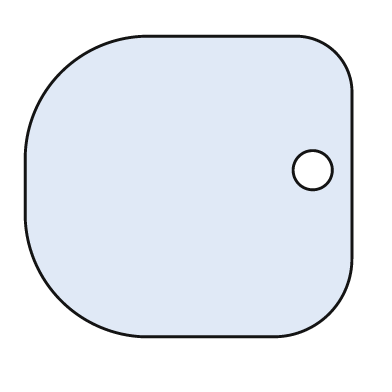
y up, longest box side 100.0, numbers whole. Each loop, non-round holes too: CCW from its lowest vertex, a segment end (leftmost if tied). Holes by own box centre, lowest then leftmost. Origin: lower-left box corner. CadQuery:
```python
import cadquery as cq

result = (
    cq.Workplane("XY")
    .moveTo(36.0, 0.0)
    .lineTo(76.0, 0.0)
    .threePointArc((93.0, 7.0), (100.0, 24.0))
    .lineTo(100.0, 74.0)
    .threePointArc((95.0, 87.0), (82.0, 92.0))
    .lineTo(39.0, 92.0)
    .threePointArc((11.0, 81.0), (0.0, 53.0))
    .lineTo(0.0, 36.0)
    .threePointArc((11.0, 11.0), (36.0, 0.0))
    .close()
    .moveTo(88.0, 51.0)
    .circle(6.0)
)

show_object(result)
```